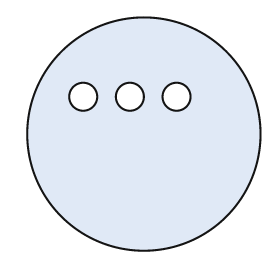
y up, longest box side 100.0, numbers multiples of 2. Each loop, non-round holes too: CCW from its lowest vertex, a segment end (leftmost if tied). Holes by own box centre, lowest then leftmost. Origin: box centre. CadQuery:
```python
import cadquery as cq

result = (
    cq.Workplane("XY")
    .moveTo(0.0, 0.0)
    .circle(50.0)
    .moveTo(-26.0, 16.0)
    .circle(6.0)
    .moveTo(-6.0, 16.0)
    .circle(6.0)
    .moveTo(14.0, 16.0)
    .circle(6.0)
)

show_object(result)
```